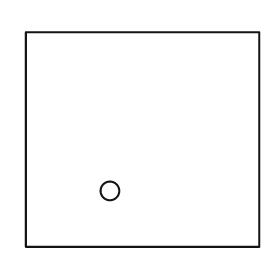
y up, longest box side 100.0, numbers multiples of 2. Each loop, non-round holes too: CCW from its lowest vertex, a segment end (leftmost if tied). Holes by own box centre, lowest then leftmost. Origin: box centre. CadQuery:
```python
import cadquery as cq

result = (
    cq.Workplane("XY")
    .moveTo(-50.0, -46.0)
    .lineTo(50.0, -46.0)
    .lineTo(50.0, 46.0)
    .lineTo(-50.0, 46.0)
    .close()
    .moveTo(-14.0, -22.0)
    .circle(4.0)
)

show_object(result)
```